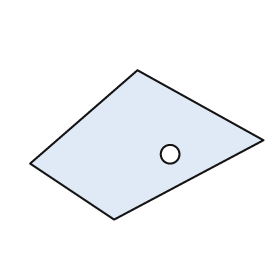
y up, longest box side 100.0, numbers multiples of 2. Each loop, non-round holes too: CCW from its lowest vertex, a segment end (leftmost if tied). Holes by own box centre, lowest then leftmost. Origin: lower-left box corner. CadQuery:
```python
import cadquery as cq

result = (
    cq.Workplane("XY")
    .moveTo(36.0, 0.0)
    .lineTo(100.0, 34.0)
    .lineTo(46.0, 64.0)
    .lineTo(0.0, 24.0)
    .close()
    .moveTo(60.0, 28.0)
    .circle(4.0)
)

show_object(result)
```